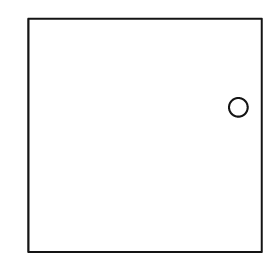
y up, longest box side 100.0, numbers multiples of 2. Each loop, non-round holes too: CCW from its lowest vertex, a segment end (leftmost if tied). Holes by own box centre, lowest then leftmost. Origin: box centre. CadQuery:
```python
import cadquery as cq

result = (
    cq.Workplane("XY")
    .moveTo(-50.0, -50.0)
    .lineTo(50.0, -50.0)
    .lineTo(50.0, 50.0)
    .lineTo(-50.0, 50.0)
    .close()
    .moveTo(40.0, 12.0)
    .circle(4.0)
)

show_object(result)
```